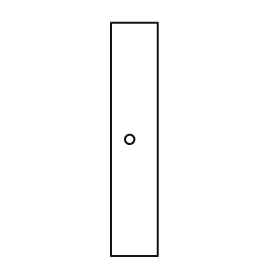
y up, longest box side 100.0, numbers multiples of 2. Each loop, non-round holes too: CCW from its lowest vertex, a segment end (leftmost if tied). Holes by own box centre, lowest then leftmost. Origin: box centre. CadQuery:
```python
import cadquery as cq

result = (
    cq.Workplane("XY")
    .moveTo(-10.0, -50.0)
    .lineTo(10.0, -50.0)
    .lineTo(10.0, 50.0)
    .lineTo(-10.0, 50.0)
    .close()
    .moveTo(-2.0, 0.0)
    .circle(2.0)
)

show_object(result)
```